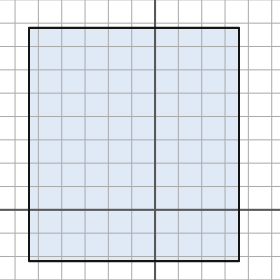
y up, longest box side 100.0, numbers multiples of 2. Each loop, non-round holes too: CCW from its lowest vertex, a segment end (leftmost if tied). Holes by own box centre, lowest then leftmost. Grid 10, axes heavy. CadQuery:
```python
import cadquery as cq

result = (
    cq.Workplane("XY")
    .moveTo(-54.0, -22.0)
    .lineTo(36.0, -22.0)
    .lineTo(36.0, 78.0)
    .lineTo(-54.0, 78.0)
    .close()
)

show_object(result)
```